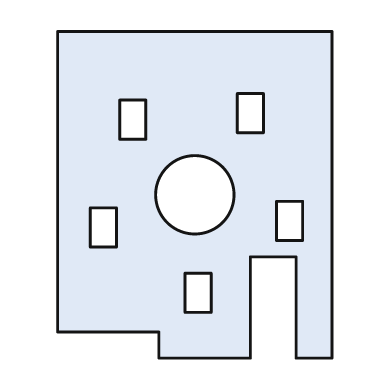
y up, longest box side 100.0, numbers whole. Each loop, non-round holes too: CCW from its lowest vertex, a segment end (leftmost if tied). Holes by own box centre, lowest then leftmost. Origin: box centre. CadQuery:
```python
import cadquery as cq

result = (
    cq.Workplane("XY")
    .moveTo(-11.0, -50.0)
    .lineTo(17.0, -50.0)
    .lineTo(17.0, -19.0)
    .lineTo(31.0, -19.0)
    .lineTo(31.0, -50.0)
    .lineTo(42.0, -50.0)
    .lineTo(42.0, 50.0)
    .lineTo(-42.0, 50.0)
    .lineTo(-42.0, -42.0)
    .lineTo(-11.0, -42.0)
    .close()
    .moveTo(-3.0, -36.0)
    .lineTo(5.0, -36.0)
    .lineTo(5.0, -24.0)
    .lineTo(-3.0, -24.0)
    .close()
    .moveTo(-32.0, -16.0)
    .lineTo(-24.0, -16.0)
    .lineTo(-24.0, -4.0)
    .lineTo(-32.0, -4.0)
    .close()
    .moveTo(25.0, -14.0)
    .lineTo(33.0, -14.0)
    .lineTo(33.0, -2.0)
    .lineTo(25.0, -2.0)
    .close()
    .moveTo(0.0, 0.0)
    .circle(12.0)
    .moveTo(-23.0, 17.0)
    .lineTo(-15.0, 17.0)
    .lineTo(-15.0, 29.0)
    .lineTo(-23.0, 29.0)
    .close()
    .moveTo(13.0, 19.0)
    .lineTo(21.0, 19.0)
    .lineTo(21.0, 31.0)
    .lineTo(13.0, 31.0)
    .close()
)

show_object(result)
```